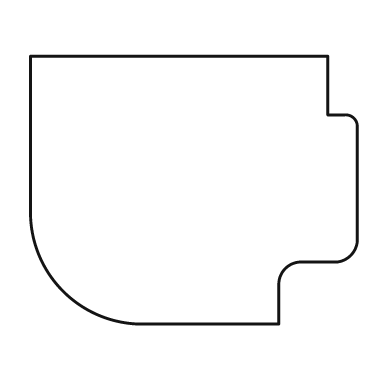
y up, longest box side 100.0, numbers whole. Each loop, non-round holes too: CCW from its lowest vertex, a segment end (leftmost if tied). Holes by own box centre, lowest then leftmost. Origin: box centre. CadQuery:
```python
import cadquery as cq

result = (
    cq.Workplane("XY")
    .moveTo(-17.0, -41.0)
    .lineTo(26.0, -41.0)
    .lineTo(26.0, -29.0)
    .threePointArc((28.0, -24.0), (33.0, -22.0))
    .lineTo(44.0, -22.0)
    .threePointArc((48.0, -20.0), (50.0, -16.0))
    .lineTo(50.0, 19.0)
    .threePointArc((49.0, 22.0), (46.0, 23.0))
    .lineTo(41.0, 23.0)
    .lineTo(41.0, 41.0)
    .lineTo(-50.0, 41.0)
    .lineTo(-50.0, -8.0)
    .threePointArc((-40.0, -31.0), (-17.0, -41.0))
    .close()
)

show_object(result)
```